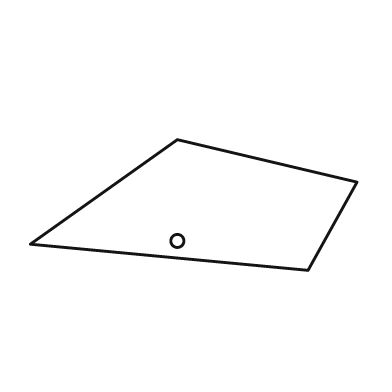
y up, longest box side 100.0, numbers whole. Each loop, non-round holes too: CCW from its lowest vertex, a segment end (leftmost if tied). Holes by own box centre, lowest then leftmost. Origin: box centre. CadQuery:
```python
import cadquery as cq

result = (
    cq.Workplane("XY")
    .moveTo(35.0, -20.0)
    .lineTo(50.0, 7.0)
    .lineTo(-5.0, 20.0)
    .lineTo(-50.0, -12.0)
    .close()
    .moveTo(-5.0, -11.0)
    .circle(2.0)
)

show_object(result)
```